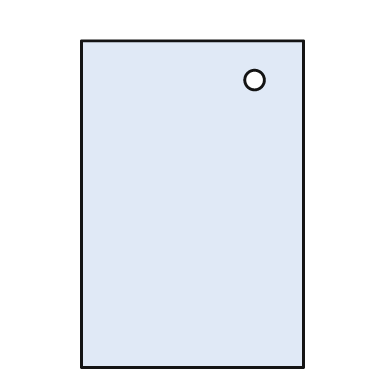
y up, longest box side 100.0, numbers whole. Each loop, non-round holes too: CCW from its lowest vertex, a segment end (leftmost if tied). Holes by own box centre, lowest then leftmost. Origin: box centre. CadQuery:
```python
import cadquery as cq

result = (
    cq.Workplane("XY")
    .moveTo(-34.0, -50.0)
    .lineTo(34.0, -50.0)
    .lineTo(34.0, 50.0)
    .lineTo(-34.0, 50.0)
    .close()
    .moveTo(19.0, 38.0)
    .circle(3.0)
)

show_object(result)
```